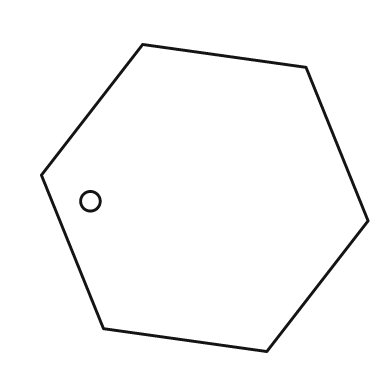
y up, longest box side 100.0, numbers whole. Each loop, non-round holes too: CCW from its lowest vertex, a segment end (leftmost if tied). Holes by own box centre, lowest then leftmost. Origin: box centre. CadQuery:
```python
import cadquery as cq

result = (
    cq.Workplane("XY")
    .moveTo(19.0, -47.0)
    .lineTo(50.0, -7.0)
    .lineTo(31.0, 40.0)
    .lineTo(-19.0, 47.0)
    .lineTo(-50.0, 7.0)
    .lineTo(-31.0, -40.0)
    .close()
    .moveTo(-35.0, -1.0)
    .circle(3.0)
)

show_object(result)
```